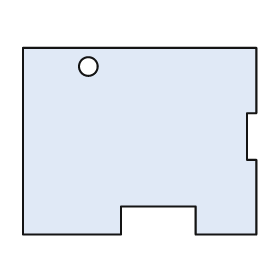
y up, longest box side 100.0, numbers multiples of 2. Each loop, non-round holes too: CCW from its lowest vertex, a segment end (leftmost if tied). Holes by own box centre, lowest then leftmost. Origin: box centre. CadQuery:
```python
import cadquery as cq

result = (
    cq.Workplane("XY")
    .moveTo(-50.0, -40.0)
    .lineTo(-8.0, -40.0)
    .lineTo(-8.0, -28.0)
    .lineTo(24.0, -28.0)
    .lineTo(24.0, -40.0)
    .lineTo(50.0, -40.0)
    .lineTo(50.0, -8.0)
    .lineTo(46.0, -8.0)
    .lineTo(46.0, 12.0)
    .lineTo(50.0, 12.0)
    .lineTo(50.0, 40.0)
    .lineTo(-50.0, 40.0)
    .close()
    .moveTo(-22.0, 32.0)
    .circle(4.0)
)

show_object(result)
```